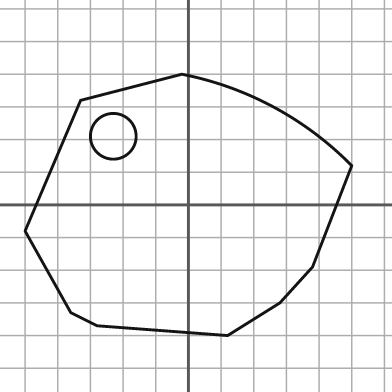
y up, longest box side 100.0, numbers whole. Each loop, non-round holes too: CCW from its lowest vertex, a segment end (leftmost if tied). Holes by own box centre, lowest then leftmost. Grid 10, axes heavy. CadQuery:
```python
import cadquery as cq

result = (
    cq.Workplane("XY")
    .moveTo(12.0, -40.0)
    .lineTo(28.0, -30.0)
    .lineTo(38.0, -19.0)
    .lineTo(50.0, 12.0)
    .threePointArc((26.0, 30.0), (-2.0, 40.0))
    .lineTo(-33.0, 32.0)
    .lineTo(-50.0, -8.0)
    .lineTo(-36.0, -33.0)
    .lineTo(-28.0, -37.0)
    .close()
    .moveTo(-23.0, 21.0)
    .circle(7.0)
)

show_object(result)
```